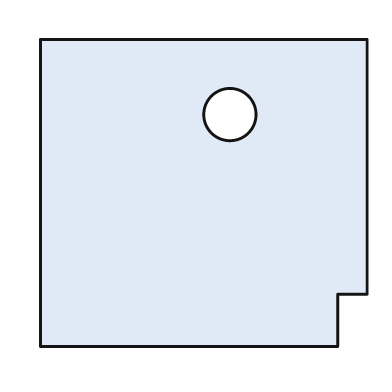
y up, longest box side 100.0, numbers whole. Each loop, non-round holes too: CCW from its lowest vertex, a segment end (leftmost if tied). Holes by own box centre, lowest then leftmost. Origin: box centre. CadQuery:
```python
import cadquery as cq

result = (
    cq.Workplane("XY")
    .moveTo(-50.0, -47.0)
    .lineTo(41.0, -47.0)
    .lineTo(41.0, -31.0)
    .lineTo(50.0, -31.0)
    .lineTo(50.0, 47.0)
    .lineTo(-50.0, 47.0)
    .close()
    .moveTo(8.0, 24.0)
    .circle(8.0)
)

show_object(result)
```